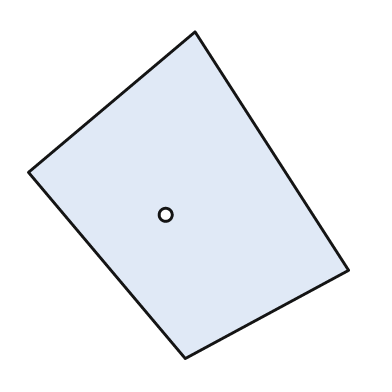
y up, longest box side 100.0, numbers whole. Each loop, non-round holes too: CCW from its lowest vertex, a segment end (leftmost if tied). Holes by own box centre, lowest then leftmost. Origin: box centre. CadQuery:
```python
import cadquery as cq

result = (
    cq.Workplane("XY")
    .moveTo(-1.0, -50.0)
    .lineTo(49.0, -23.0)
    .lineTo(2.0, 50.0)
    .lineTo(-49.0, 7.0)
    .close()
    .moveTo(-7.0, -6.0)
    .circle(2.0)
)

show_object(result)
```